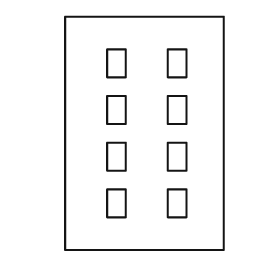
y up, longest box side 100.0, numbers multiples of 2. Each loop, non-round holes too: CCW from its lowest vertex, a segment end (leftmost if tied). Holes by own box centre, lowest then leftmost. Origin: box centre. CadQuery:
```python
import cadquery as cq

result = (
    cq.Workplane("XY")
    .moveTo(-34.0, -50.0)
    .lineTo(34.0, -50.0)
    .lineTo(34.0, 50.0)
    .lineTo(-34.0, 50.0)
    .close()
    .moveTo(-16.0, -36.0)
    .lineTo(-8.0, -36.0)
    .lineTo(-8.0, -24.0)
    .lineTo(-16.0, -24.0)
    .close()
    .moveTo(10.0, -36.0)
    .lineTo(18.0, -36.0)
    .lineTo(18.0, -24.0)
    .lineTo(10.0, -24.0)
    .close()
    .moveTo(-16.0, -16.0)
    .lineTo(-8.0, -16.0)
    .lineTo(-8.0, -4.0)
    .lineTo(-16.0, -4.0)
    .close()
    .moveTo(10.0, -16.0)
    .lineTo(18.0, -16.0)
    .lineTo(18.0, -4.0)
    .lineTo(10.0, -4.0)
    .close()
    .moveTo(-16.0, 4.0)
    .lineTo(-8.0, 4.0)
    .lineTo(-8.0, 16.0)
    .lineTo(-16.0, 16.0)
    .close()
    .moveTo(10.0, 4.0)
    .lineTo(18.0, 4.0)
    .lineTo(18.0, 16.0)
    .lineTo(10.0, 16.0)
    .close()
    .moveTo(-16.0, 24.0)
    .lineTo(-8.0, 24.0)
    .lineTo(-8.0, 36.0)
    .lineTo(-16.0, 36.0)
    .close()
    .moveTo(10.0, 24.0)
    .lineTo(18.0, 24.0)
    .lineTo(18.0, 36.0)
    .lineTo(10.0, 36.0)
    .close()
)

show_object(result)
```